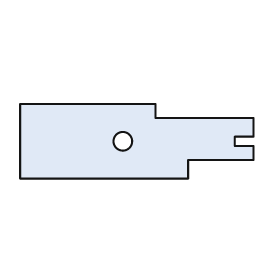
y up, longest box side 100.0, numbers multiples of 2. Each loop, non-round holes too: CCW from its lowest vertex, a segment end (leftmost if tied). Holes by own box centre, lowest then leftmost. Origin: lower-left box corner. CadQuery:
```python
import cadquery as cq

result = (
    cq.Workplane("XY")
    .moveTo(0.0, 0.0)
    .lineTo(72.0, 0.0)
    .lineTo(72.0, 8.0)
    .lineTo(100.0, 8.0)
    .lineTo(100.0, 14.0)
    .lineTo(92.0, 14.0)
    .lineTo(92.0, 18.0)
    .lineTo(100.0, 18.0)
    .lineTo(100.0, 26.0)
    .lineTo(58.0, 26.0)
    .lineTo(58.0, 32.0)
    .lineTo(0.0, 32.0)
    .close()
    .moveTo(44.0, 16.0)
    .circle(4.0)
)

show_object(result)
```